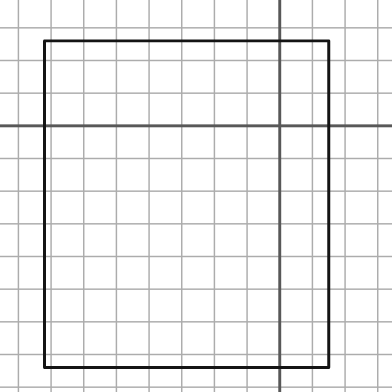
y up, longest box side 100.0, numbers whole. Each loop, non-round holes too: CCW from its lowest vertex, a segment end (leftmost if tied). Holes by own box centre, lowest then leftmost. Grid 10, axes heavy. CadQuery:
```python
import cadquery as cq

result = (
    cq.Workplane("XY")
    .moveTo(-72.0, -74.0)
    .lineTo(15.0, -74.0)
    .lineTo(15.0, 26.0)
    .lineTo(-72.0, 26.0)
    .close()
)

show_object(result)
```